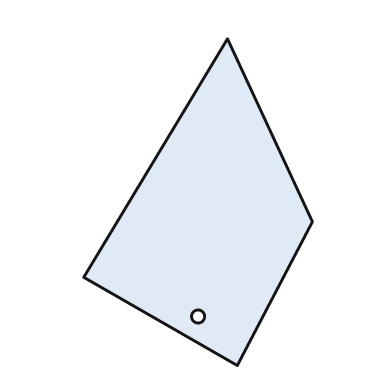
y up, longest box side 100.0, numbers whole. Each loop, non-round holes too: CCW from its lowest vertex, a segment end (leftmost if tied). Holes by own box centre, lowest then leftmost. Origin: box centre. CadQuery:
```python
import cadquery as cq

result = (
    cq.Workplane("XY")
    .moveTo(12.0, -50.0)
    .lineTo(35.0, -6.0)
    .lineTo(9.0, 50.0)
    .lineTo(-35.0, -23.0)
    .close()
    .moveTo(0.0, -35.0)
    .circle(2.0)
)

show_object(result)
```